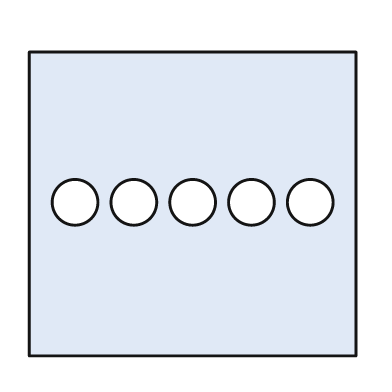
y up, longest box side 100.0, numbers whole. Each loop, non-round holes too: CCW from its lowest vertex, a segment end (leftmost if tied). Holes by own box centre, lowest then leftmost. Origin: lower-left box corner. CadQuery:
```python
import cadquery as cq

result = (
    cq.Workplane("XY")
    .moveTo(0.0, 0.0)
    .lineTo(100.0, 0.0)
    .lineTo(100.0, 93.0)
    .lineTo(0.0, 93.0)
    .close()
    .moveTo(14.0, 47.0)
    .circle(7.0)
    .moveTo(32.0, 47.0)
    .circle(7.0)
    .moveTo(50.0, 47.0)
    .circle(7.0)
    .moveTo(68.0, 47.0)
    .circle(7.0)
    .moveTo(86.0, 47.0)
    .circle(7.0)
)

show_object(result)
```